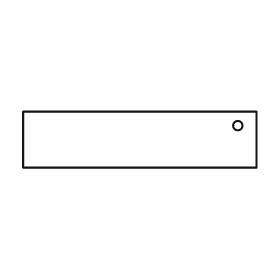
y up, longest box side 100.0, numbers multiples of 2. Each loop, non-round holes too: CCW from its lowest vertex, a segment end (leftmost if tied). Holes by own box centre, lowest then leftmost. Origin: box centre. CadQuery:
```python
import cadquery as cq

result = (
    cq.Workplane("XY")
    .moveTo(-50.0, -12.0)
    .lineTo(50.0, -12.0)
    .lineTo(50.0, 12.0)
    .lineTo(-50.0, 12.0)
    .close()
    .moveTo(42.0, 6.0)
    .circle(2.0)
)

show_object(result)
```